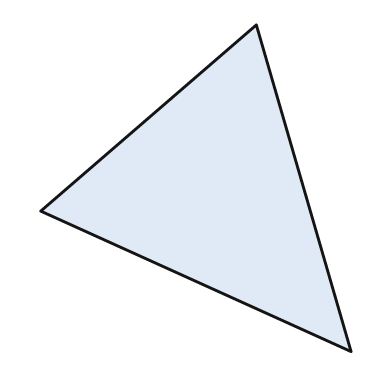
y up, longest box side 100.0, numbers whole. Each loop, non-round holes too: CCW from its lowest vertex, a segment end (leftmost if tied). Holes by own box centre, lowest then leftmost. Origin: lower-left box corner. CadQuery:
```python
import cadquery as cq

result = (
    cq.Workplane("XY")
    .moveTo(95.0, 0.0)
    .lineTo(66.0, 100.0)
    .lineTo(0.0, 43.0)
    .close()
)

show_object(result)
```